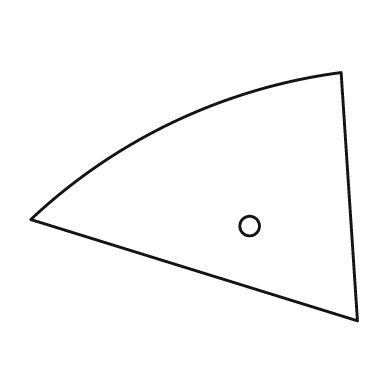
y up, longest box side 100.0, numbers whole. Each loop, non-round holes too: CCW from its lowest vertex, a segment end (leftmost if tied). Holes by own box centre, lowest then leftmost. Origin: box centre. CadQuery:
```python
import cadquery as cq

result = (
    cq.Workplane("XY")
    .moveTo(50.0, -38.0)
    .lineTo(45.0, 38.0)
    .threePointArc((-6.0, 23.0), (-50.0, -7.0))
    .close()
    .moveTo(17.0, -9.0)
    .circle(3.0)
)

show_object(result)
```